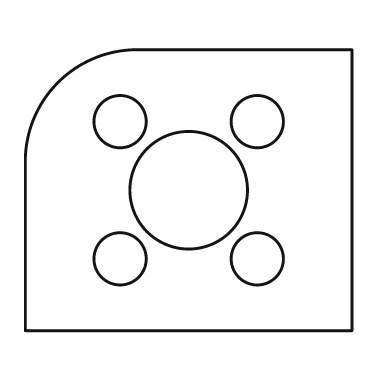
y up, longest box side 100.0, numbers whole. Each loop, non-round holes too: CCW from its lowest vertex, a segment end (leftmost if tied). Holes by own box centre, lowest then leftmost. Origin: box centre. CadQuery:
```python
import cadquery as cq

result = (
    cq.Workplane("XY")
    .moveTo(-50.0, -43.0)
    .lineTo(50.0, -43.0)
    .lineTo(50.0, 43.0)
    .lineTo(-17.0, 43.0)
    .threePointArc((-40.0, 33.0), (-50.0, 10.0))
    .close()
    .moveTo(-21.0, -21.0)
    .circle(8.0)
    .moveTo(21.0, -21.0)
    .circle(8.0)
    .moveTo(0.0, 0.0)
    .circle(18.0)
    .moveTo(-21.0, 21.0)
    .circle(8.0)
    .moveTo(21.0, 21.0)
    .circle(8.0)
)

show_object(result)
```